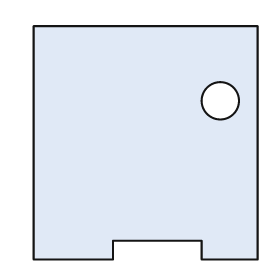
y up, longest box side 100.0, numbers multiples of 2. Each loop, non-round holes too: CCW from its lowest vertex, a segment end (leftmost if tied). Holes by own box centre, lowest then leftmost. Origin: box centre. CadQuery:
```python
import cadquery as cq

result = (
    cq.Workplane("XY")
    .moveTo(-48.0, -50.0)
    .lineTo(-14.0, -50.0)
    .lineTo(-14.0, -42.0)
    .lineTo(24.0, -42.0)
    .lineTo(24.0, -50.0)
    .lineTo(48.0, -50.0)
    .lineTo(48.0, 50.0)
    .lineTo(-48.0, 50.0)
    .close()
    .moveTo(32.0, 18.0)
    .circle(8.0)
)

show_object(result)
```